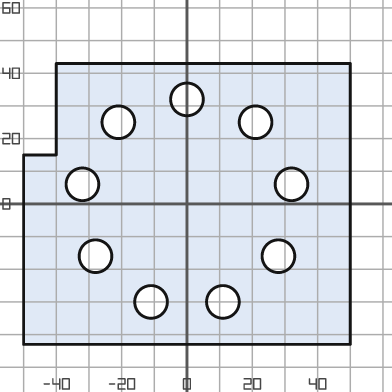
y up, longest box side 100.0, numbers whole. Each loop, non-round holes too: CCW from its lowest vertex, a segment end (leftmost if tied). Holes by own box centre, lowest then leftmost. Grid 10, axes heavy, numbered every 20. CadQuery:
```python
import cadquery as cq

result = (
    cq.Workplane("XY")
    .moveTo(-50.0, -43.0)
    .lineTo(50.0, -43.0)
    .lineTo(50.0, 43.0)
    .lineTo(-40.0, 43.0)
    .lineTo(-40.0, 15.0)
    .lineTo(-50.0, 15.0)
    .close()
    .moveTo(-11.0, -30.0)
    .circle(5.0)
    .moveTo(11.0, -30.0)
    .circle(5.0)
    .moveTo(-28.0, -16.0)
    .circle(5.0)
    .moveTo(28.0, -16.0)
    .circle(5.0)
    .moveTo(-32.0, 6.0)
    .circle(5.0)
    .moveTo(32.0, 6.0)
    .circle(5.0)
    .moveTo(-21.0, 25.0)
    .circle(5.0)
    .moveTo(21.0, 25.0)
    .circle(5.0)
    .moveTo(0.0, 32.0)
    .circle(5.0)
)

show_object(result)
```